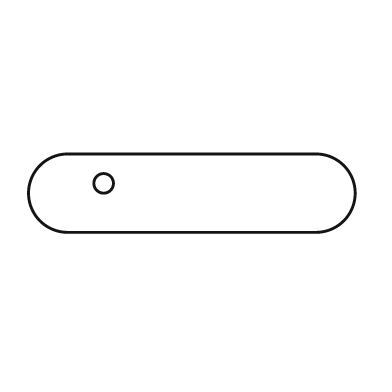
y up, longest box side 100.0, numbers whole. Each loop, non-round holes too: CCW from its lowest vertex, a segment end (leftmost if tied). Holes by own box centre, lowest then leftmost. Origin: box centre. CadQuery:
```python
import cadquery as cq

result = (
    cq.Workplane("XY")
    .moveTo(-38.0, -12.0)
    .lineTo(38.0, -12.0)
    .threePointArc((50.0, 0.0), (38.0, 12.0))
    .lineTo(-38.0, 12.0)
    .threePointArc((-50.0, 0.0), (-38.0, -12.0))
    .close()
    .moveTo(-27.0, 3.0)
    .circle(3.0)
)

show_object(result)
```